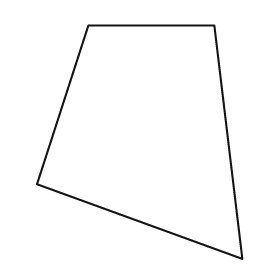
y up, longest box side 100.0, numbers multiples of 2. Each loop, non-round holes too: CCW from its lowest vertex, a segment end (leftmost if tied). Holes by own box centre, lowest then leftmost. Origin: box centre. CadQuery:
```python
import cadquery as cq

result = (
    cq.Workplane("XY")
    .moveTo(44.0, -50.0)
    .lineTo(32.0, 50.0)
    .lineTo(-22.0, 50.0)
    .lineTo(-44.0, -18.0)
    .close()
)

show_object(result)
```